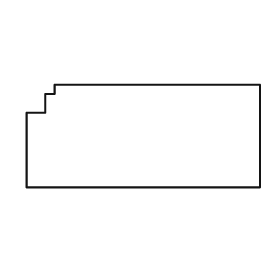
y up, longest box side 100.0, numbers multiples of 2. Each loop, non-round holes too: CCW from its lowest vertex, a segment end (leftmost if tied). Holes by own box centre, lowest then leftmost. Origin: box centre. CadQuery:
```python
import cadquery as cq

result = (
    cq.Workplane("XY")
    .moveTo(-50.0, -22.0)
    .lineTo(50.0, -22.0)
    .lineTo(50.0, 22.0)
    .lineTo(-38.0, 22.0)
    .lineTo(-38.0, 18.0)
    .lineTo(-42.0, 18.0)
    .lineTo(-42.0, 10.0)
    .lineTo(-50.0, 10.0)
    .close()
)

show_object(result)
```